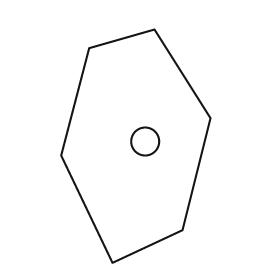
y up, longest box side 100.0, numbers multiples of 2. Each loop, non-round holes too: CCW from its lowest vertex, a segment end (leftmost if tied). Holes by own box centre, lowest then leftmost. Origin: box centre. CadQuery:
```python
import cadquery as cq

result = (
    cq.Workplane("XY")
    .moveTo(-10.0, -50.0)
    .lineTo(20.0, -36.0)
    .lineTo(32.0, 12.0)
    .lineTo(8.0, 50.0)
    .lineTo(-20.0, 42.0)
    .lineTo(-32.0, -4.0)
    .close()
    .moveTo(4.0, 2.0)
    .circle(6.0)
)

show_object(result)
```